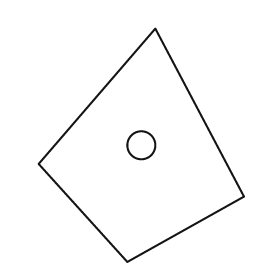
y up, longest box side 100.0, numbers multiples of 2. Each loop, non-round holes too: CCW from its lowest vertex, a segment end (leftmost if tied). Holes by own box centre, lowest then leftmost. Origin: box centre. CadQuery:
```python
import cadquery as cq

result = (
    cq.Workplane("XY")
    .moveTo(-6.0, -50.0)
    .lineTo(44.0, -22.0)
    .lineTo(6.0, 50.0)
    .lineTo(-44.0, -8.0)
    .close()
    .moveTo(0.0, 0.0)
    .circle(6.0)
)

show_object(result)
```